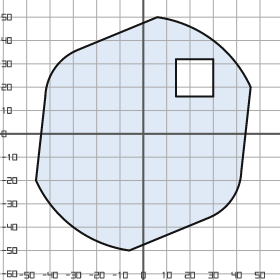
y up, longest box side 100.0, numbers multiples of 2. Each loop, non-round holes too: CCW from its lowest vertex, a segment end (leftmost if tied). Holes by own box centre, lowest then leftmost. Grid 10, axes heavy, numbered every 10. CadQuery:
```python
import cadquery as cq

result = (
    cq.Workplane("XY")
    .moveTo(-6.0, -50.0)
    .lineTo(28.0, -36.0)
    .threePointArc((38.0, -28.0), (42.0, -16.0))
    .lineTo(46.0, 20.0)
    .threePointArc((30.0, 40.0), (6.0, 50.0))
    .lineTo(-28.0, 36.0)
    .threePointArc((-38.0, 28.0), (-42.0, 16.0))
    .lineTo(-46.0, -20.0)
    .threePointArc((-30.0, -40.0), (-6.0, -50.0))
    .close()
    .moveTo(14.0, 16.0)
    .lineTo(30.0, 16.0)
    .lineTo(30.0, 32.0)
    .lineTo(14.0, 32.0)
    .close()
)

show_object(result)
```